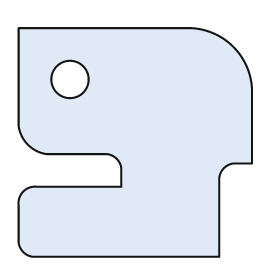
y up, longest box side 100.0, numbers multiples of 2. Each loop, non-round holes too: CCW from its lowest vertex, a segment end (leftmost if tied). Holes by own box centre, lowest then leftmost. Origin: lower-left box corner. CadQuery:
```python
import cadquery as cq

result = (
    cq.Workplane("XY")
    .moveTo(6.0, 0.0)
    .lineTo(86.0, 0.0)
    .lineTo(86.0, 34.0)
    .threePointArc((88.0, 38.0), (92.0, 40.0))
    .lineTo(100.0, 40.0)
    .lineTo(100.0, 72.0)
    .threePointArc((92.0, 90.0), (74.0, 98.0))
    .lineTo(0.0, 98.0)
    .lineTo(0.0, 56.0)
    .threePointArc((4.0, 48.0), (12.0, 44.0))
    .lineTo(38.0, 44.0)
    .threePointArc((42.0, 42.0), (44.0, 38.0))
    .lineTo(44.0, 30.0)
    .lineTo(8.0, 30.0)
    .threePointArc((2.0, 28.0), (0.0, 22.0))
    .lineTo(0.0, 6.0)
    .threePointArc((2.0, 2.0), (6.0, 0.0))
    .close()
    .moveTo(22.0, 76.0)
    .circle(8.0)
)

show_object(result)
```